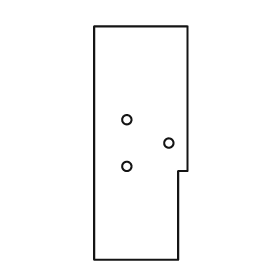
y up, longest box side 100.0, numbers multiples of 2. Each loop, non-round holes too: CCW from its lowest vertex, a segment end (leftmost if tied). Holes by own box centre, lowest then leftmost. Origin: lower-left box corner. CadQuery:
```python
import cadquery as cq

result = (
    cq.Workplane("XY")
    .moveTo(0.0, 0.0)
    .lineTo(36.0, 0.0)
    .lineTo(36.0, 38.0)
    .lineTo(40.0, 38.0)
    .lineTo(40.0, 100.0)
    .lineTo(0.0, 100.0)
    .close()
    .moveTo(14.0, 40.0)
    .circle(2.0)
    .moveTo(32.0, 50.0)
    .circle(2.0)
    .moveTo(14.0, 60.0)
    .circle(2.0)
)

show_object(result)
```